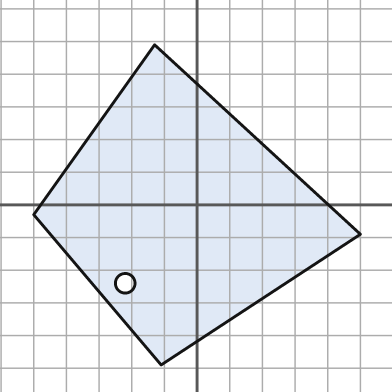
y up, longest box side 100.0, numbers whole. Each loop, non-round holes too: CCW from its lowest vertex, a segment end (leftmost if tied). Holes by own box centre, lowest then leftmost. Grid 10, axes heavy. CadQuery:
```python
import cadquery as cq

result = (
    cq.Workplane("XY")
    .moveTo(-11.0, -49.0)
    .lineTo(50.0, -9.0)
    .lineTo(-13.0, 49.0)
    .lineTo(-50.0, -3.0)
    .close()
    .moveTo(-22.0, -24.0)
    .circle(3.0)
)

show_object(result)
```